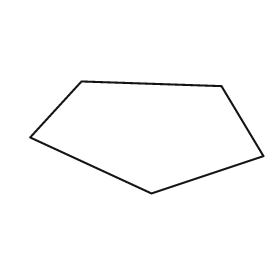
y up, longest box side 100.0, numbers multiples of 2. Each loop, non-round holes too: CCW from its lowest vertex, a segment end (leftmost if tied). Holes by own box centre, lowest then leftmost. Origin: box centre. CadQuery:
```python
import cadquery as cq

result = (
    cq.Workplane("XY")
    .moveTo(2.0, -24.0)
    .lineTo(50.0, -8.0)
    .lineTo(32.0, 22.0)
    .lineTo(-28.0, 24.0)
    .lineTo(-50.0, 0.0)
    .close()
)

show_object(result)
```